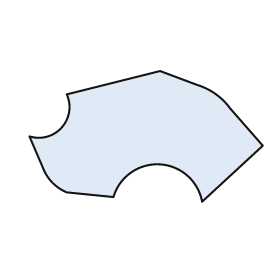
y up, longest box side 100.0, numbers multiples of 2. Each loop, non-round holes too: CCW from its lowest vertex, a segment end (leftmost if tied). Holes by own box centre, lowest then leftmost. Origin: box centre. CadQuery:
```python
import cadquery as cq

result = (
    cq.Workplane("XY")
    .moveTo(24.0, -28.0)
    .lineTo(50.0, -4.0)
    .lineTo(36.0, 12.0)
    .threePointArc((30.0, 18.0), (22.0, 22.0))
    .lineTo(6.0, 28.0)
    .lineTo(-34.0, 18.0)
    .threePointArc((-36.0, 4.0), (-50.0, 0.0))
    .lineTo(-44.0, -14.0)
    .threePointArc((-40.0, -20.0), (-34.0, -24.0))
    .lineTo(-14.0, -26.0)
    .threePointArc((6.0, -12.0), (24.0, -28.0))
    .close()
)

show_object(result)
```